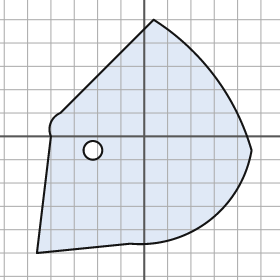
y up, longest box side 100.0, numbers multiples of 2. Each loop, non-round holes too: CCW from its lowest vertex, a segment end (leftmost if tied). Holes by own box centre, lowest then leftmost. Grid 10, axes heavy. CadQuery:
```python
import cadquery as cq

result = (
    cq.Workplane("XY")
    .moveTo(-46.0, -50.0)
    .lineTo(-6.0, -46.0)
    .threePointArc((28.0, -36.0), (46.0, -6.0))
    .threePointArc((30.0, 26.0), (4.0, 50.0))
    .lineTo(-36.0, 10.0)
    .threePointArc((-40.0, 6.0), (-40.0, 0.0))
    .close()
    .moveTo(-22.0, -6.0)
    .circle(4.0)
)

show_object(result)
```